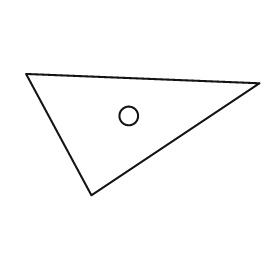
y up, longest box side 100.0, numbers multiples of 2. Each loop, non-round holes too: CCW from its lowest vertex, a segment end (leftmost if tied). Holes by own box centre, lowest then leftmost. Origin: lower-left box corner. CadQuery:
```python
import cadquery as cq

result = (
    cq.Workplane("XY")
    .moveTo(28.0, 0.0)
    .lineTo(100.0, 48.0)
    .lineTo(0.0, 52.0)
    .close()
    .moveTo(44.0, 34.0)
    .circle(4.0)
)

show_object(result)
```